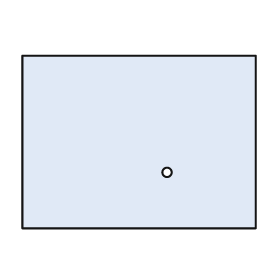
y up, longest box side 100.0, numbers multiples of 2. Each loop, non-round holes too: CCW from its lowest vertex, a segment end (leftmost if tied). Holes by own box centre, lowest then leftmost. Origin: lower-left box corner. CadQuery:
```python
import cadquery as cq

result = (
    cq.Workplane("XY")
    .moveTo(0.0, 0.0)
    .lineTo(100.0, 0.0)
    .lineTo(100.0, 74.0)
    .lineTo(0.0, 74.0)
    .close()
    .moveTo(62.0, 24.0)
    .circle(2.0)
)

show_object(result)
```